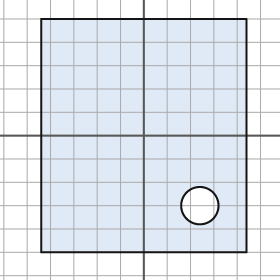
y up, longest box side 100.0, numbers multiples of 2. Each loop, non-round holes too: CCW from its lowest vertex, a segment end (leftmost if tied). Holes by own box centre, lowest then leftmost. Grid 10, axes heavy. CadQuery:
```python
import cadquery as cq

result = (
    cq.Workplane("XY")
    .moveTo(-44.0, -50.0)
    .lineTo(44.0, -50.0)
    .lineTo(44.0, 50.0)
    .lineTo(-44.0, 50.0)
    .close()
    .moveTo(24.0, -30.0)
    .circle(8.0)
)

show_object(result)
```